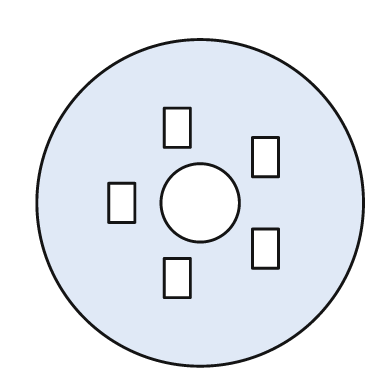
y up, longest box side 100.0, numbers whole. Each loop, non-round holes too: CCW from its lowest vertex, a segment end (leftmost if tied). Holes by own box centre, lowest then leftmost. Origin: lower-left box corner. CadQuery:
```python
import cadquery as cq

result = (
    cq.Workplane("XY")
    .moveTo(50.0, 50.0)
    .circle(50.0)
    .moveTo(39.0, 21.0)
    .lineTo(47.0, 21.0)
    .lineTo(47.0, 33.0)
    .lineTo(39.0, 33.0)
    .close()
    .moveTo(66.0, 30.0)
    .lineTo(74.0, 30.0)
    .lineTo(74.0, 42.0)
    .lineTo(66.0, 42.0)
    .close()
    .moveTo(22.0, 44.0)
    .lineTo(30.0, 44.0)
    .lineTo(30.0, 56.0)
    .lineTo(22.0, 56.0)
    .close()
    .moveTo(50.0, 50.0)
    .circle(12.0)
    .moveTo(66.0, 58.0)
    .lineTo(74.0, 58.0)
    .lineTo(74.0, 70.0)
    .lineTo(66.0, 70.0)
    .close()
    .moveTo(39.0, 67.0)
    .lineTo(47.0, 67.0)
    .lineTo(47.0, 79.0)
    .lineTo(39.0, 79.0)
    .close()
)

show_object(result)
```